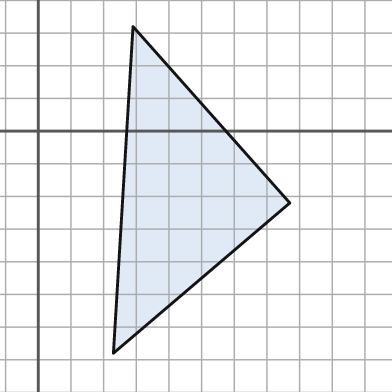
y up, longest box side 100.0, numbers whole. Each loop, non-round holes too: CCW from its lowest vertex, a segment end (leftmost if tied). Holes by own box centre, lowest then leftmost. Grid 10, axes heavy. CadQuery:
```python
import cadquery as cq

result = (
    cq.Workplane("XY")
    .moveTo(23.0, -68.0)
    .lineTo(77.0, -22.0)
    .lineTo(29.0, 32.0)
    .close()
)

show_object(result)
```